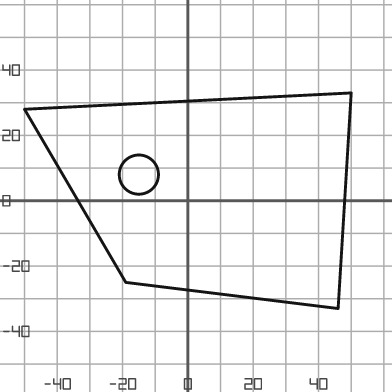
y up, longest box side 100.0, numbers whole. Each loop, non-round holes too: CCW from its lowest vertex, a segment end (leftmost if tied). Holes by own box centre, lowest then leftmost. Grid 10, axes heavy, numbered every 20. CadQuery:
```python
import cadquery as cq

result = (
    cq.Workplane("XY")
    .moveTo(46.0, -33.0)
    .lineTo(50.0, 33.0)
    .lineTo(-50.0, 28.0)
    .lineTo(-19.0, -25.0)
    .close()
    .moveTo(-15.0, 8.0)
    .circle(6.0)
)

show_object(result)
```